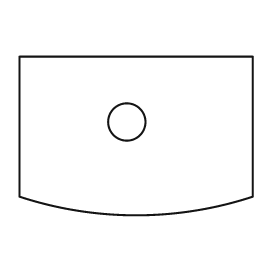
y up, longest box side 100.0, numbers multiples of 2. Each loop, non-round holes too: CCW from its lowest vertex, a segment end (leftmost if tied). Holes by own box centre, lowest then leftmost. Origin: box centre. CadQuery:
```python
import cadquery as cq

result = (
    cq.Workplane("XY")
    .moveTo(-50.0, -26.0)
    .threePointArc((0.0, -34.0), (50.0, -26.0))
    .lineTo(50.0, 34.0)
    .lineTo(-50.0, 34.0)
    .close()
    .moveTo(-4.0, 6.0)
    .circle(8.0)
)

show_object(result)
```